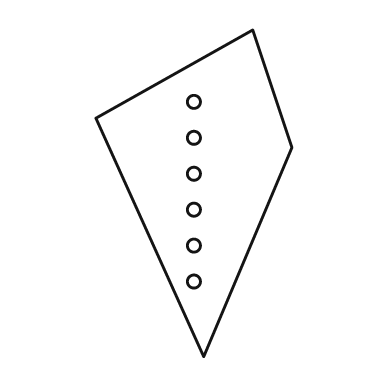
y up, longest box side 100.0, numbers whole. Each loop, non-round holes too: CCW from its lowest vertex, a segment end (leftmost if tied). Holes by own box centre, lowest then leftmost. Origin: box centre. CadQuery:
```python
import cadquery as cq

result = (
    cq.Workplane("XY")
    .moveTo(3.0, -50.0)
    .lineTo(30.0, 14.0)
    .lineTo(18.0, 50.0)
    .lineTo(-30.0, 23.0)
    .close()
    .moveTo(0.0, -27.0)
    .circle(2.0)
    .moveTo(0.0, -16.0)
    .circle(2.0)
    .moveTo(0.0, -5.0)
    .circle(2.0)
    .moveTo(0.0, 6.0)
    .circle(2.0)
    .moveTo(0.0, 17.0)
    .circle(2.0)
    .moveTo(0.0, 28.0)
    .circle(2.0)
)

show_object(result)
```